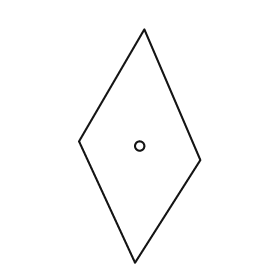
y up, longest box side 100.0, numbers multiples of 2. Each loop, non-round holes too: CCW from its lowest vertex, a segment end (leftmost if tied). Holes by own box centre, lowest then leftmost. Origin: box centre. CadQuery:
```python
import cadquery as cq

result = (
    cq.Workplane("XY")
    .moveTo(-2.0, -50.0)
    .lineTo(26.0, -6.0)
    .lineTo(2.0, 50.0)
    .lineTo(-26.0, 2.0)
    .close()
    .moveTo(0.0, 0.0)
    .circle(2.0)
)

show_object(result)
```